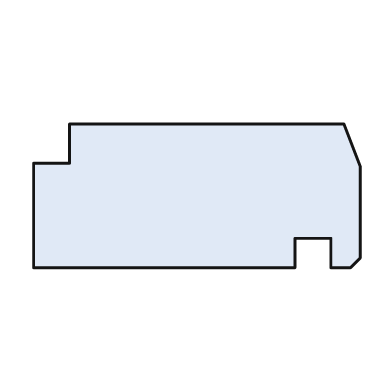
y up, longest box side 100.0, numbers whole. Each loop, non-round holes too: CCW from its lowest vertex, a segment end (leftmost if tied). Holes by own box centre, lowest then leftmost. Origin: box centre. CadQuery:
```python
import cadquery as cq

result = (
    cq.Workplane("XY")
    .moveTo(-50.0, -22.0)
    .lineTo(30.0, -22.0)
    .lineTo(30.0, -13.0)
    .lineTo(41.0, -13.0)
    .lineTo(41.0, -22.0)
    .lineTo(47.0, -22.0)
    .lineTo(50.0, -19.0)
    .lineTo(50.0, 9.0)
    .lineTo(45.0, 22.0)
    .lineTo(-39.0, 22.0)
    .lineTo(-39.0, 10.0)
    .lineTo(-50.0, 10.0)
    .close()
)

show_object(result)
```